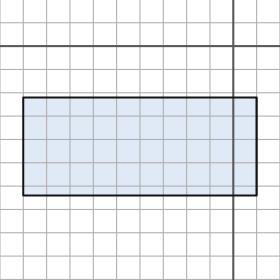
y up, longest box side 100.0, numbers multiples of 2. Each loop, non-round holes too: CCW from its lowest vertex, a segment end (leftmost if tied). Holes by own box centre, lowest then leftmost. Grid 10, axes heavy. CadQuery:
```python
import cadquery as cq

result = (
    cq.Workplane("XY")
    .moveTo(-90.0, -64.0)
    .lineTo(10.0, -64.0)
    .lineTo(10.0, -22.0)
    .lineTo(-90.0, -22.0)
    .close()
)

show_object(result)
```